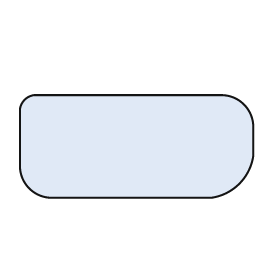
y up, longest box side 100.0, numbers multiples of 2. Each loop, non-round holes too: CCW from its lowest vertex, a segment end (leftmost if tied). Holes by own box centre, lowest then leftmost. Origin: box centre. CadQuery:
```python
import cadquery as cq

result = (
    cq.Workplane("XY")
    .moveTo(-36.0, -22.0)
    .lineTo(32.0, -22.0)
    .threePointArc((44.0, -16.0), (50.0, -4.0))
    .lineTo(50.0, 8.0)
    .threePointArc((46.0, 18.0), (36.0, 22.0))
    .lineTo(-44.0, 22.0)
    .threePointArc((-48.0, 20.0), (-50.0, 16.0))
    .lineTo(-50.0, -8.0)
    .threePointArc((-46.0, -18.0), (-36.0, -22.0))
    .close()
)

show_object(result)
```